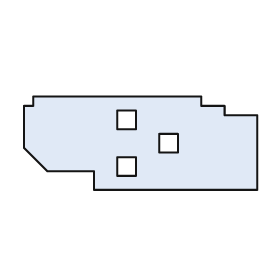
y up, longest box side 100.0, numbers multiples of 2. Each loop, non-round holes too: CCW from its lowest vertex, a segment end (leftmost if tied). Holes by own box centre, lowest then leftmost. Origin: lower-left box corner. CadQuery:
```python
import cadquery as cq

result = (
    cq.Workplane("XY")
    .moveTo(30.0, 0.0)
    .lineTo(100.0, 0.0)
    .lineTo(100.0, 32.0)
    .lineTo(86.0, 32.0)
    .lineTo(86.0, 36.0)
    .lineTo(76.0, 36.0)
    .lineTo(76.0, 40.0)
    .lineTo(4.0, 40.0)
    .lineTo(4.0, 36.0)
    .lineTo(0.0, 36.0)
    .lineTo(0.0, 18.0)
    .lineTo(10.0, 8.0)
    .lineTo(30.0, 8.0)
    .close()
    .moveTo(40.0, 6.0)
    .lineTo(48.0, 6.0)
    .lineTo(48.0, 14.0)
    .lineTo(40.0, 14.0)
    .close()
    .moveTo(58.0, 16.0)
    .lineTo(66.0, 16.0)
    .lineTo(66.0, 24.0)
    .lineTo(58.0, 24.0)
    .close()
    .moveTo(40.0, 26.0)
    .lineTo(48.0, 26.0)
    .lineTo(48.0, 34.0)
    .lineTo(40.0, 34.0)
    .close()
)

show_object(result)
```